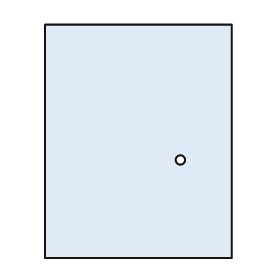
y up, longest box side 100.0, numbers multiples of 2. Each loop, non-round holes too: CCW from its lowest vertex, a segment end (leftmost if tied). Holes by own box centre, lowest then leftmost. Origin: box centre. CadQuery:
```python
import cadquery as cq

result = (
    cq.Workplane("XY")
    .moveTo(-40.0, -50.0)
    .lineTo(40.0, -50.0)
    .lineTo(40.0, 50.0)
    .lineTo(-40.0, 50.0)
    .close()
    .moveTo(18.0, -8.0)
    .circle(2.0)
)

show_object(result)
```